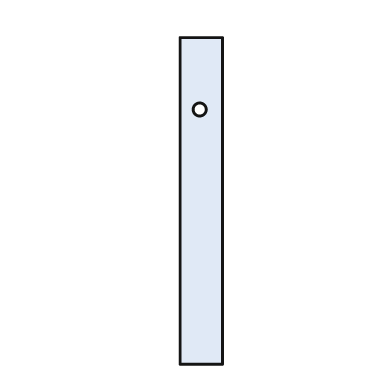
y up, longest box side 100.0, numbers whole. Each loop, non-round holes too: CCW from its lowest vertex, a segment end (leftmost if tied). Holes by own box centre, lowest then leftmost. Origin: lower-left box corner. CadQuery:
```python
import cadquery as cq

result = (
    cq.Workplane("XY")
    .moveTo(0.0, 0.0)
    .lineTo(13.0, 0.0)
    .lineTo(13.0, 100.0)
    .lineTo(0.0, 100.0)
    .close()
    .moveTo(6.0, 78.0)
    .circle(2.0)
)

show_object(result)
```